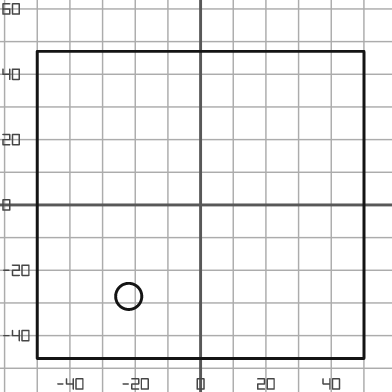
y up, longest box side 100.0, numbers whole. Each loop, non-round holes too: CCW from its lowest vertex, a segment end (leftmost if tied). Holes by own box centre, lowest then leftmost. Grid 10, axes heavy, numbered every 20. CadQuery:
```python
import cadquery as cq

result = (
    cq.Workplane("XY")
    .moveTo(-50.0, -47.0)
    .lineTo(50.0, -47.0)
    .lineTo(50.0, 47.0)
    .lineTo(-50.0, 47.0)
    .close()
    .moveTo(-22.0, -28.0)
    .circle(4.0)
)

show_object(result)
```